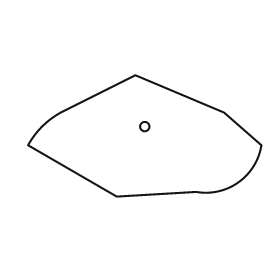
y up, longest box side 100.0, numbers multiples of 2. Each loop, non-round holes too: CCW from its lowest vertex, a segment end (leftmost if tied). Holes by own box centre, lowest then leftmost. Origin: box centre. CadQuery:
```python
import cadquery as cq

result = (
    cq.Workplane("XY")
    .moveTo(-12.0, -26.0)
    .lineTo(22.0, -24.0)
    .threePointArc((40.0, -20.0), (50.0, -4.0))
    .lineTo(34.0, 10.0)
    .lineTo(-4.0, 26.0)
    .lineTo(-36.0, 10.0)
    .threePointArc((-44.0, 4.0), (-50.0, -4.0))
    .close()
    .moveTo(0.0, 4.0)
    .circle(2.0)
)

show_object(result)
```